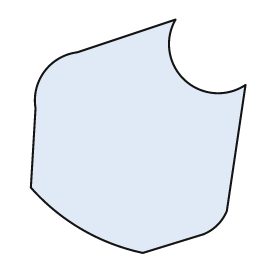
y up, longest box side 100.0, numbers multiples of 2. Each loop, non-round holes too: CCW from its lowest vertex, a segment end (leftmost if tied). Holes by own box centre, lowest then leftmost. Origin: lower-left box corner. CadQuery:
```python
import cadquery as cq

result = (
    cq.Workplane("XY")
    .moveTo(48.0, 0.0)
    .lineTo(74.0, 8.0)
    .threePointArc((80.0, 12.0), (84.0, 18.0))
    .lineTo(92.0, 72.0)
    .threePointArc((66.0, 74.0), (62.0, 100.0))
    .lineTo(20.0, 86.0)
    .threePointArc((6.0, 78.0), (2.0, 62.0))
    .lineTo(0.0, 28.0)
    .threePointArc((22.0, 10.0), (48.0, 0.0))
    .close()
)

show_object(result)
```